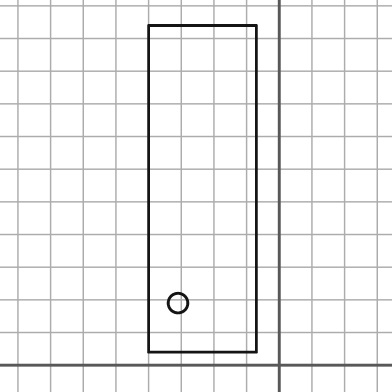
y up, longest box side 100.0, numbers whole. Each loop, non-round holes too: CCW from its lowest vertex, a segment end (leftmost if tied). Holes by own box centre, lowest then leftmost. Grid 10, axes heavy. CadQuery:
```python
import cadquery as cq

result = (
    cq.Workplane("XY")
    .moveTo(-40.0, 4.0)
    .lineTo(-7.0, 4.0)
    .lineTo(-7.0, 104.0)
    .lineTo(-40.0, 104.0)
    .close()
    .moveTo(-31.0, 19.0)
    .circle(3.0)
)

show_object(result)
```